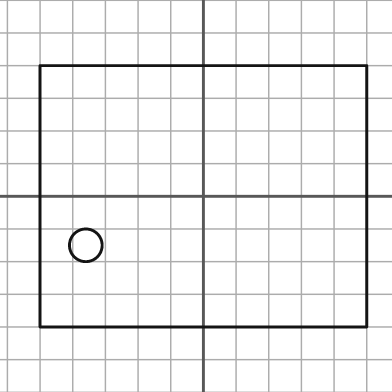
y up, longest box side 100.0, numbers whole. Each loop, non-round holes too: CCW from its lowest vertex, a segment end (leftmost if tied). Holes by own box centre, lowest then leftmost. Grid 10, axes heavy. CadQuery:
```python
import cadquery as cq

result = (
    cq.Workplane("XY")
    .moveTo(-50.0, -40.0)
    .lineTo(50.0, -40.0)
    .lineTo(50.0, 40.0)
    .lineTo(-50.0, 40.0)
    .close()
    .moveTo(-36.0, -15.0)
    .circle(5.0)
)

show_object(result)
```